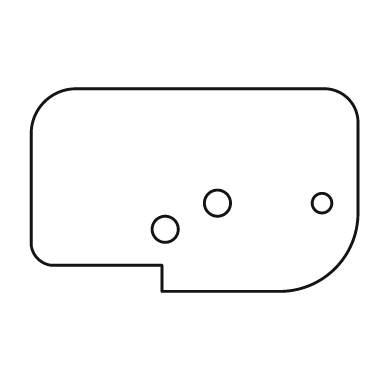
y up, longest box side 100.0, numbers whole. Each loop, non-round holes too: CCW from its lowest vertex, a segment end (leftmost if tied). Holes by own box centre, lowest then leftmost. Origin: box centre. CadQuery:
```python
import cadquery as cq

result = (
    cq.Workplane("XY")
    .moveTo(-10.0, -31.0)
    .lineTo(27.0, -31.0)
    .threePointArc((43.0, -24.0), (50.0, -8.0))
    .lineTo(50.0, 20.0)
    .threePointArc((47.0, 28.0), (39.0, 31.0))
    .lineTo(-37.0, 31.0)
    .threePointArc((-46.0, 27.0), (-50.0, 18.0))
    .lineTo(-50.0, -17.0)
    .threePointArc((-48.0, -21.0), (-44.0, -23.0))
    .lineTo(-10.0, -23.0)
    .close()
    .moveTo(-9.0, -12.0)
    .circle(4.0)
    .moveTo(7.0, -4.0)
    .circle(4.0)
    .moveTo(39.0, -4.0)
    .circle(3.0)
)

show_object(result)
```